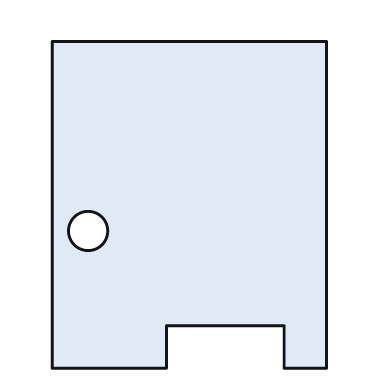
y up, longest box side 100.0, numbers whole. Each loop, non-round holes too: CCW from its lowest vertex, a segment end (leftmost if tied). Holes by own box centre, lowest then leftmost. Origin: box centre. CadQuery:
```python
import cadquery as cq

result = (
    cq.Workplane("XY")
    .moveTo(-42.0, -50.0)
    .lineTo(-7.0, -50.0)
    .lineTo(-7.0, -37.0)
    .lineTo(29.0, -37.0)
    .lineTo(29.0, -50.0)
    .lineTo(42.0, -50.0)
    .lineTo(42.0, 50.0)
    .lineTo(-42.0, 50.0)
    .close()
    .moveTo(-31.0, -8.0)
    .circle(6.0)
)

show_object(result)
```